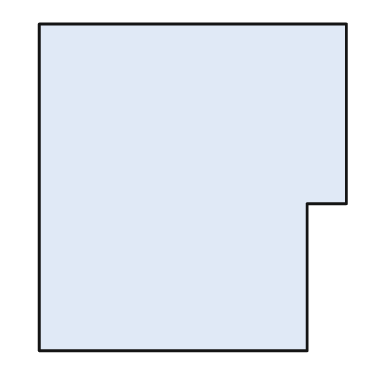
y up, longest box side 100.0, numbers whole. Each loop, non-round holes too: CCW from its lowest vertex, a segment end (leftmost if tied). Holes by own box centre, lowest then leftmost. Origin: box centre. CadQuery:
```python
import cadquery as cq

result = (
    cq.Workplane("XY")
    .moveTo(-47.0, -50.0)
    .lineTo(35.0, -50.0)
    .lineTo(35.0, -5.0)
    .lineTo(47.0, -5.0)
    .lineTo(47.0, 50.0)
    .lineTo(-47.0, 50.0)
    .close()
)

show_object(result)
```